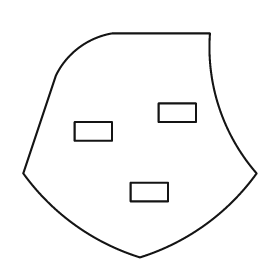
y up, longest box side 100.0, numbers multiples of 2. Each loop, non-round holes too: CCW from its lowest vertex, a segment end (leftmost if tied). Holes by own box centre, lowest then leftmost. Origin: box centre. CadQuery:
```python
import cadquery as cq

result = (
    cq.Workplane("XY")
    .moveTo(0.0, -48.0)
    .threePointArc((28.0, -34.0), (50.0, -12.0))
    .threePointArc((34.0, 16.0), (30.0, 48.0))
    .lineTo(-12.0, 48.0)
    .threePointArc((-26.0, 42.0), (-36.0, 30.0))
    .lineTo(-50.0, -12.0)
    .threePointArc((-28.0, -34.0), (0.0, -48.0))
    .close()
    .moveTo(-4.0, -24.0)
    .lineTo(12.0, -24.0)
    .lineTo(12.0, -16.0)
    .lineTo(-4.0, -16.0)
    .close()
    .moveTo(-28.0, 2.0)
    .lineTo(-12.0, 2.0)
    .lineTo(-12.0, 10.0)
    .lineTo(-28.0, 10.0)
    .close()
    .moveTo(8.0, 10.0)
    .lineTo(24.0, 10.0)
    .lineTo(24.0, 18.0)
    .lineTo(8.0, 18.0)
    .close()
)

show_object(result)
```